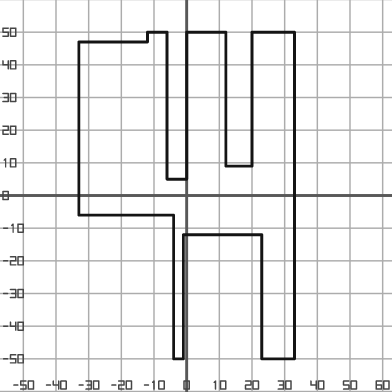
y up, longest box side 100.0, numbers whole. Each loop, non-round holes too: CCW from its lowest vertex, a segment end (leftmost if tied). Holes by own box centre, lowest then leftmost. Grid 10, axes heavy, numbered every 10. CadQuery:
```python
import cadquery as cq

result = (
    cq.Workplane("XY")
    .moveTo(-4.0, -50.0)
    .lineTo(-1.0, -50.0)
    .lineTo(-1.0, -12.0)
    .lineTo(23.0, -12.0)
    .lineTo(23.0, -50.0)
    .lineTo(33.0, -50.0)
    .lineTo(33.0, 50.0)
    .lineTo(20.0, 50.0)
    .lineTo(20.0, 9.0)
    .lineTo(12.0, 9.0)
    .lineTo(12.0, 50.0)
    .lineTo(0.0, 50.0)
    .lineTo(0.0, 5.0)
    .lineTo(-6.0, 5.0)
    .lineTo(-6.0, 50.0)
    .lineTo(-12.0, 50.0)
    .lineTo(-12.0, 47.0)
    .lineTo(-33.0, 47.0)
    .lineTo(-33.0, -6.0)
    .lineTo(-4.0, -6.0)
    .close()
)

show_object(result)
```